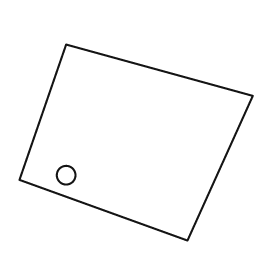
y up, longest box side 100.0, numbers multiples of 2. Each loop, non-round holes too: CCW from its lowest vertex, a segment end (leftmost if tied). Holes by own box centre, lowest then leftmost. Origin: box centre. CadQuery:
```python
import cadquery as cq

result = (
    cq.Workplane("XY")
    .moveTo(22.0, -42.0)
    .lineTo(50.0, 20.0)
    .lineTo(-30.0, 42.0)
    .lineTo(-50.0, -16.0)
    .close()
    .moveTo(-30.0, -14.0)
    .circle(4.0)
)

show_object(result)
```